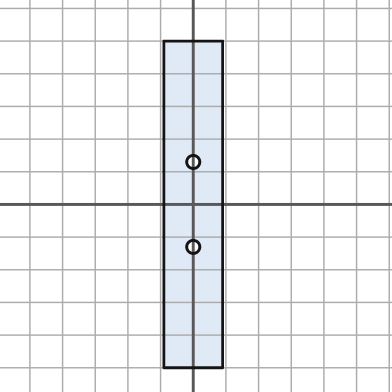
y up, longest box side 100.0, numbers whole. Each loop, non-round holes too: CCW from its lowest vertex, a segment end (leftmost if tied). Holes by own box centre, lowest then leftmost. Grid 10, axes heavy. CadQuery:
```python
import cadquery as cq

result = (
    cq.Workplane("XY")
    .moveTo(-9.0, -50.0)
    .lineTo(9.0, -50.0)
    .lineTo(9.0, 50.0)
    .lineTo(-9.0, 50.0)
    .close()
    .moveTo(0.0, -13.0)
    .circle(2.0)
    .moveTo(0.0, 13.0)
    .circle(2.0)
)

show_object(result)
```